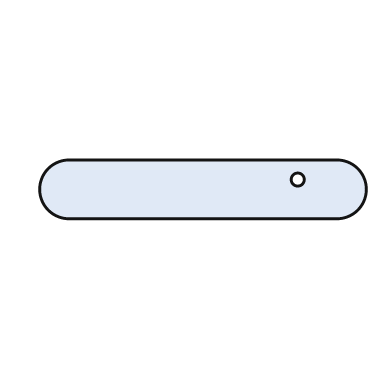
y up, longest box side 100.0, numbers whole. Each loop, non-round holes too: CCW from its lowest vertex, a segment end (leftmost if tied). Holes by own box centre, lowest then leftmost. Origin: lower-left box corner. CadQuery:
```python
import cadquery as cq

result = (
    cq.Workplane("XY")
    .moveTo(9.0, 0.0)
    .lineTo(91.0, 0.0)
    .threePointArc((100.0, 9.0), (91.0, 18.0))
    .lineTo(9.0, 18.0)
    .threePointArc((0.0, 9.0), (9.0, 0.0))
    .close()
    .moveTo(79.0, 12.0)
    .circle(2.0)
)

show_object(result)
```